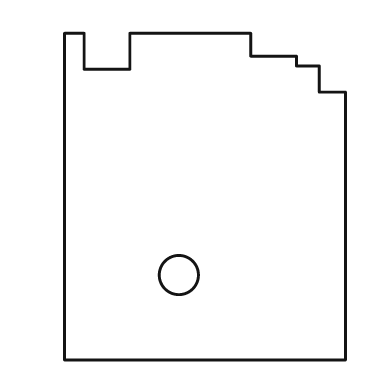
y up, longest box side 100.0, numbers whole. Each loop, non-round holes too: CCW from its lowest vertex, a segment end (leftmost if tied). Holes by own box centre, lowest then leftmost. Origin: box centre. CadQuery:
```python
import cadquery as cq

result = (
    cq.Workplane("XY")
    .moveTo(-43.0, -50.0)
    .lineTo(43.0, -50.0)
    .lineTo(43.0, 32.0)
    .lineTo(35.0, 32.0)
    .lineTo(35.0, 40.0)
    .lineTo(28.0, 40.0)
    .lineTo(28.0, 43.0)
    .lineTo(14.0, 43.0)
    .lineTo(14.0, 50.0)
    .lineTo(-23.0, 50.0)
    .lineTo(-23.0, 39.0)
    .lineTo(-37.0, 39.0)
    .lineTo(-37.0, 50.0)
    .lineTo(-43.0, 50.0)
    .close()
    .moveTo(-8.0, -24.0)
    .circle(6.0)
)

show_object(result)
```